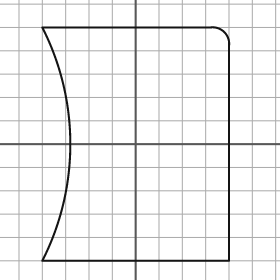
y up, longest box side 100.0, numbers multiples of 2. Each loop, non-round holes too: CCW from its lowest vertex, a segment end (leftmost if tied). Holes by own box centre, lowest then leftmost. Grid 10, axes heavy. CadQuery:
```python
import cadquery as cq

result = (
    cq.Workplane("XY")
    .moveTo(-40.0, -50.0)
    .lineTo(40.0, -50.0)
    .lineTo(40.0, 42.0)
    .threePointArc((38.0, 48.0), (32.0, 50.0))
    .lineTo(-40.0, 50.0)
    .threePointArc((-28.0, 0.0), (-40.0, -50.0))
    .close()
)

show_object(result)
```